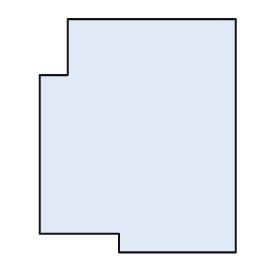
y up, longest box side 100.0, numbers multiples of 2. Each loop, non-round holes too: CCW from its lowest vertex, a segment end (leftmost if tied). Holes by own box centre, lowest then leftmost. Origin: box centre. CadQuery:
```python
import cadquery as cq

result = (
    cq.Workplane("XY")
    .moveTo(-8.0, -50.0)
    .lineTo(42.0, -50.0)
    .lineTo(42.0, 50.0)
    .lineTo(-30.0, 50.0)
    .lineTo(-30.0, 26.0)
    .lineTo(-42.0, 26.0)
    .lineTo(-42.0, -42.0)
    .lineTo(-8.0, -42.0)
    .close()
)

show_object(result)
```